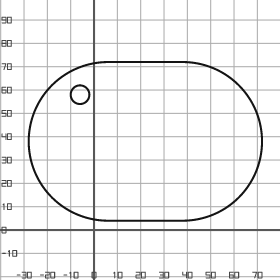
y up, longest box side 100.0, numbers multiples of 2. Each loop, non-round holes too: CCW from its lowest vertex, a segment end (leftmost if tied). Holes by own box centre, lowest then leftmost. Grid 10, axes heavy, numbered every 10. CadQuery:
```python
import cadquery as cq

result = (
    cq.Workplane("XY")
    .moveTo(6.0, 4.0)
    .lineTo(38.0, 4.0)
    .threePointArc((72.0, 38.0), (38.0, 72.0))
    .lineTo(6.0, 72.0)
    .threePointArc((-28.0, 38.0), (6.0, 4.0))
    .close()
    .moveTo(-6.0, 58.0)
    .circle(4.0)
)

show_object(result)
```